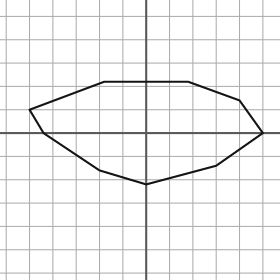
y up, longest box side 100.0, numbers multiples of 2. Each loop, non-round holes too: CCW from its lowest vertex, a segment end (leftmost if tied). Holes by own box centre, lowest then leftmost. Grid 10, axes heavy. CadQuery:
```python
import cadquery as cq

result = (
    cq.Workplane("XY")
    .moveTo(0.0, -22.0)
    .lineTo(30.0, -14.0)
    .lineTo(50.0, 0.0)
    .lineTo(40.0, 14.0)
    .lineTo(18.0, 22.0)
    .lineTo(-18.0, 22.0)
    .lineTo(-50.0, 10.0)
    .lineTo(-44.0, 0.0)
    .lineTo(-20.0, -16.0)
    .close()
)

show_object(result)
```